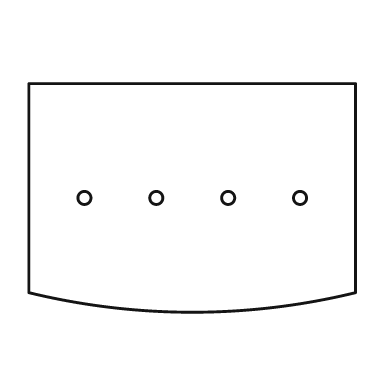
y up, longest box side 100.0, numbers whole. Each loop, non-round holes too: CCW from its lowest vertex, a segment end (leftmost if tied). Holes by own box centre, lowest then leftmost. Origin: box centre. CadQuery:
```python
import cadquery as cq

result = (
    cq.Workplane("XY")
    .moveTo(-50.0, -29.0)
    .threePointArc((0.0, -35.0), (50.0, -29.0))
    .lineTo(50.0, 35.0)
    .lineTo(-50.0, 35.0)
    .close()
    .moveTo(-33.0, 0.0)
    .circle(2.0)
    .moveTo(-11.0, 0.0)
    .circle(2.0)
    .moveTo(11.0, 0.0)
    .circle(2.0)
    .moveTo(33.0, 0.0)
    .circle(2.0)
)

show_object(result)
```